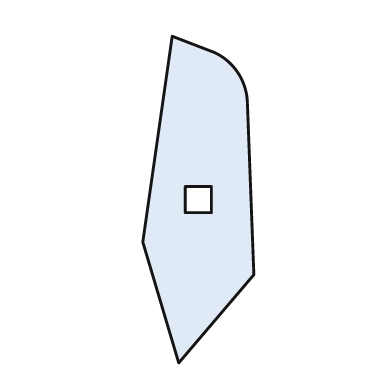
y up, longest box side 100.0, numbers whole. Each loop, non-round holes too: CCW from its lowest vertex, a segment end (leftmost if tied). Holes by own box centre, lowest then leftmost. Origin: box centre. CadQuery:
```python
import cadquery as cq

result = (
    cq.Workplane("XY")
    .moveTo(-6.0, -50.0)
    .lineTo(17.0, -23.0)
    .lineTo(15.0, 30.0)
    .threePointArc((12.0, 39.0), (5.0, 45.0))
    .lineTo(-8.0, 50.0)
    .lineTo(-17.0, -13.0)
    .close()
    .moveTo(-4.0, -4.0)
    .lineTo(4.0, -4.0)
    .lineTo(4.0, 4.0)
    .lineTo(-4.0, 4.0)
    .close()
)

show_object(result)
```